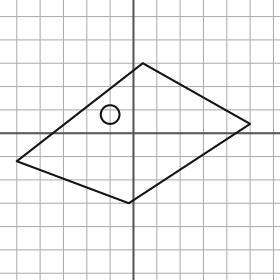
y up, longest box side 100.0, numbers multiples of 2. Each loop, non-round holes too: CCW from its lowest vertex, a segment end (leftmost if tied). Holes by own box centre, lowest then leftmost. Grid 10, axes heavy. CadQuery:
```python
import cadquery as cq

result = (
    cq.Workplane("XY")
    .moveTo(-2.0, -30.0)
    .lineTo(50.0, 4.0)
    .lineTo(4.0, 30.0)
    .lineTo(-50.0, -12.0)
    .close()
    .moveTo(-10.0, 8.0)
    .circle(4.0)
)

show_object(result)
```